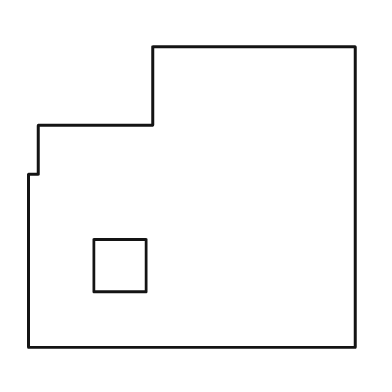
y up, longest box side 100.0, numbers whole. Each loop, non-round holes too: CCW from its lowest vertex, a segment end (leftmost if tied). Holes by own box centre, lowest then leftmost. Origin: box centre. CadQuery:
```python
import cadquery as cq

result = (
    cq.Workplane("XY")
    .moveTo(-50.0, -46.0)
    .lineTo(50.0, -46.0)
    .lineTo(50.0, 46.0)
    .lineTo(-12.0, 46.0)
    .lineTo(-12.0, 22.0)
    .lineTo(-47.0, 22.0)
    .lineTo(-47.0, 7.0)
    .lineTo(-50.0, 7.0)
    .close()
    .moveTo(-30.0, -29.0)
    .lineTo(-14.0, -29.0)
    .lineTo(-14.0, -13.0)
    .lineTo(-30.0, -13.0)
    .close()
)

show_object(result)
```